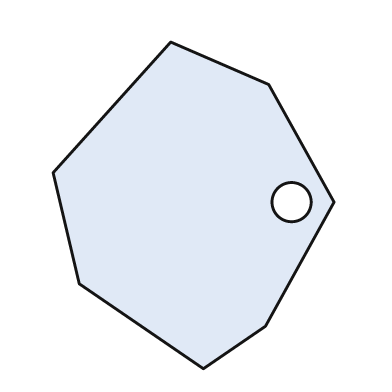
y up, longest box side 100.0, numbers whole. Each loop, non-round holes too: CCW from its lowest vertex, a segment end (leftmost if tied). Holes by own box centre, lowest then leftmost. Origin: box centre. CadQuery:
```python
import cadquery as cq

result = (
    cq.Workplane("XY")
    .moveTo(3.0, -50.0)
    .lineTo(22.0, -37.0)
    .lineTo(43.0, 1.0)
    .lineTo(23.0, 37.0)
    .lineTo(-7.0, 50.0)
    .lineTo(-43.0, 10.0)
    .lineTo(-35.0, -24.0)
    .close()
    .moveTo(30.0, 1.0)
    .circle(6.0)
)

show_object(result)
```